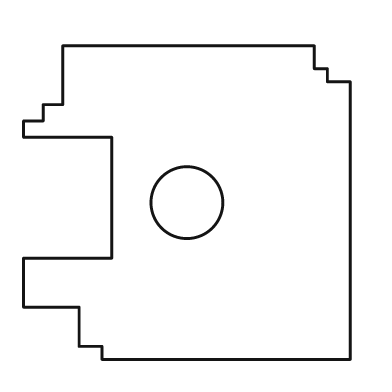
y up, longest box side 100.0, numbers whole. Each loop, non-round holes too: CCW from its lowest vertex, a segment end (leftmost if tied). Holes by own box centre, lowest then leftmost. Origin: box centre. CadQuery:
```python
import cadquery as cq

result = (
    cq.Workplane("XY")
    .moveTo(-26.0, -48.0)
    .lineTo(50.0, -48.0)
    .lineTo(50.0, 37.0)
    .lineTo(43.0, 37.0)
    .lineTo(43.0, 41.0)
    .lineTo(39.0, 41.0)
    .lineTo(39.0, 48.0)
    .lineTo(-38.0, 48.0)
    .lineTo(-38.0, 30.0)
    .lineTo(-44.0, 30.0)
    .lineTo(-44.0, 25.0)
    .lineTo(-50.0, 25.0)
    .lineTo(-50.0, 20.0)
    .lineTo(-23.0, 20.0)
    .lineTo(-23.0, -17.0)
    .lineTo(-50.0, -17.0)
    .lineTo(-50.0, -32.0)
    .lineTo(-33.0, -32.0)
    .lineTo(-33.0, -44.0)
    .lineTo(-26.0, -44.0)
    .close()
    .moveTo(0.0, 0.0)
    .circle(11.0)
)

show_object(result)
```